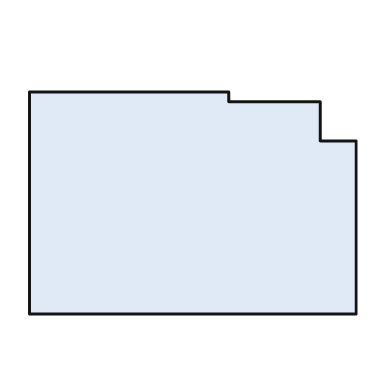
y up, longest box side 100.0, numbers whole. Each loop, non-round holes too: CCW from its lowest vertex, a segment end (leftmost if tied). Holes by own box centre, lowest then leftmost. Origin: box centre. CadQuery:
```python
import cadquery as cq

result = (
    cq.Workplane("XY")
    .moveTo(-50.0, -34.0)
    .lineTo(50.0, -34.0)
    .lineTo(50.0, 19.0)
    .lineTo(39.0, 19.0)
    .lineTo(39.0, 31.0)
    .lineTo(11.0, 31.0)
    .lineTo(11.0, 34.0)
    .lineTo(-50.0, 34.0)
    .close()
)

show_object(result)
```